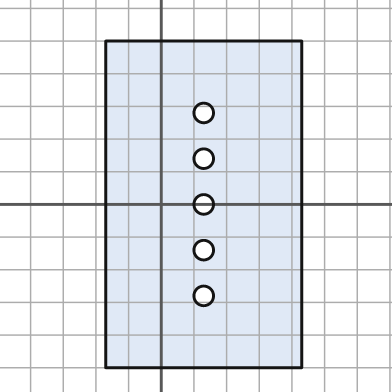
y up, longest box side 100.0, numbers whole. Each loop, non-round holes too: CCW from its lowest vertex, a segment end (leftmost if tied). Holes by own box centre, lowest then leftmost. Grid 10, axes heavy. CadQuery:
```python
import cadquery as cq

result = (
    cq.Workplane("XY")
    .moveTo(-17.0, -50.0)
    .lineTo(43.0, -50.0)
    .lineTo(43.0, 50.0)
    .lineTo(-17.0, 50.0)
    .close()
    .moveTo(13.0, -28.0)
    .circle(3.0)
    .moveTo(13.0, -14.0)
    .circle(3.0)
    .moveTo(13.0, 0.0)
    .circle(3.0)
    .moveTo(13.0, 14.0)
    .circle(3.0)
    .moveTo(13.0, 28.0)
    .circle(3.0)
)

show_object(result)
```